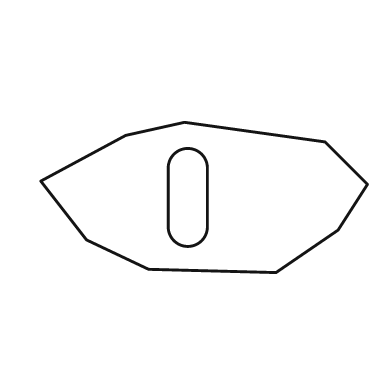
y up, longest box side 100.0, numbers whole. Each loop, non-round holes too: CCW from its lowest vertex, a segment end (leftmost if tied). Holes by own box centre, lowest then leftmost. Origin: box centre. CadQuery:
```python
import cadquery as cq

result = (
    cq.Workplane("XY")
    .moveTo(22.0, -23.0)
    .lineTo(41.0, -10.0)
    .lineTo(50.0, 4.0)
    .lineTo(37.0, 17.0)
    .lineTo(-6.0, 23.0)
    .lineTo(-24.0, 19.0)
    .lineTo(-50.0, 5.0)
    .lineTo(-36.0, -13.0)
    .lineTo(-17.0, -22.0)
    .close()
    .moveTo(-11.0, -9.0)
    .threePointArc((-5.0, -15.0), (1.0, -9.0))
    .lineTo(1.0, 9.0)
    .threePointArc((-5.0, 15.0), (-11.0, 9.0))
    .close()
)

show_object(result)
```